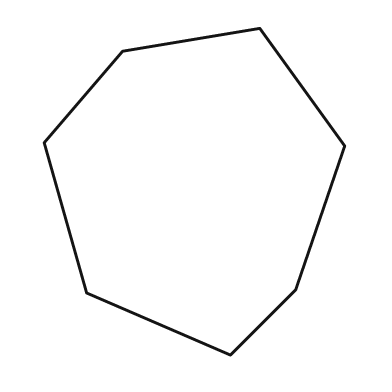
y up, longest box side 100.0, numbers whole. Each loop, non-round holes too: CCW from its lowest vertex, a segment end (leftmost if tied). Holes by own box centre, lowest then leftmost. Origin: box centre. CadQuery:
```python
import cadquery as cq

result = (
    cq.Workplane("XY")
    .moveTo(11.0, -50.0)
    .lineTo(31.0, -30.0)
    .lineTo(46.0, 14.0)
    .lineTo(20.0, 50.0)
    .lineTo(-22.0, 43.0)
    .lineTo(-46.0, 15.0)
    .lineTo(-33.0, -31.0)
    .close()
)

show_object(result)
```